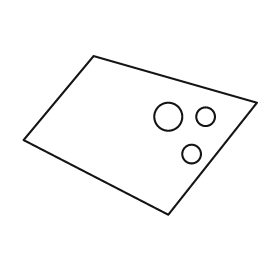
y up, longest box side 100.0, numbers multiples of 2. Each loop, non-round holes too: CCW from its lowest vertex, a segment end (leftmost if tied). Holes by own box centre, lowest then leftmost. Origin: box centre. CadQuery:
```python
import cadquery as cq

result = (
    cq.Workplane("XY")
    .moveTo(12.0, -34.0)
    .lineTo(50.0, 14.0)
    .lineTo(-20.0, 34.0)
    .lineTo(-50.0, -2.0)
    .close()
    .moveTo(22.0, -8.0)
    .circle(4.0)
    .moveTo(12.0, 8.0)
    .circle(6.0)
    .moveTo(28.0, 8.0)
    .circle(4.0)
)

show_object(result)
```